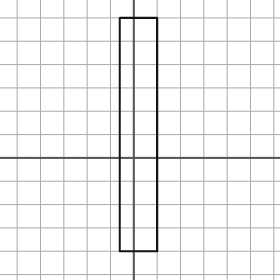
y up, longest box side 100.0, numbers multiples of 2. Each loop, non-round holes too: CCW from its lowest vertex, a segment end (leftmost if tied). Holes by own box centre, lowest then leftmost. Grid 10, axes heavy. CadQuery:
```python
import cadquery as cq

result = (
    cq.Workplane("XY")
    .moveTo(-6.0, -40.0)
    .lineTo(10.0, -40.0)
    .lineTo(10.0, 60.0)
    .lineTo(-6.0, 60.0)
    .close()
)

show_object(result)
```